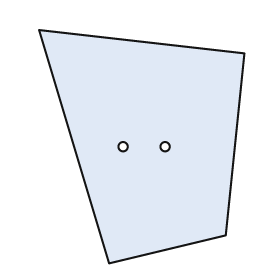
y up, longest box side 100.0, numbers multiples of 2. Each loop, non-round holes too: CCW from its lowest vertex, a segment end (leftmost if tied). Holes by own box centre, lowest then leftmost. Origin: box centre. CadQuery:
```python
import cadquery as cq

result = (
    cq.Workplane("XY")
    .moveTo(-14.0, -50.0)
    .lineTo(36.0, -38.0)
    .lineTo(44.0, 40.0)
    .lineTo(-44.0, 50.0)
    .close()
    .moveTo(-8.0, 0.0)
    .circle(2.0)
    .moveTo(10.0, 0.0)
    .circle(2.0)
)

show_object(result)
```